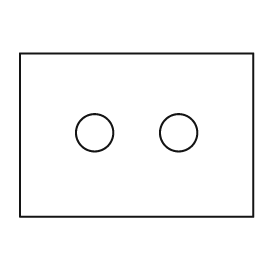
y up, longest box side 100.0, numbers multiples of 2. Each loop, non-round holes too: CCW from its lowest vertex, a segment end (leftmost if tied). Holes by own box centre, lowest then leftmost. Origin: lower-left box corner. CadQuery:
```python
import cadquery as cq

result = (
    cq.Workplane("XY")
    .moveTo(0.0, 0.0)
    .lineTo(100.0, 0.0)
    .lineTo(100.0, 70.0)
    .lineTo(0.0, 70.0)
    .close()
    .moveTo(32.0, 36.0)
    .circle(8.0)
    .moveTo(68.0, 36.0)
    .circle(8.0)
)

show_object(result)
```